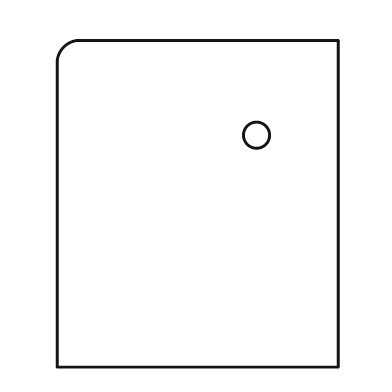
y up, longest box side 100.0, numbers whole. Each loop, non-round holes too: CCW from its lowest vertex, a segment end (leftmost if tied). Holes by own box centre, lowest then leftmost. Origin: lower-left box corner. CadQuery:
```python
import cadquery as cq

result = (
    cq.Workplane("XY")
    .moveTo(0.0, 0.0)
    .lineTo(86.0, 0.0)
    .lineTo(86.0, 100.0)
    .lineTo(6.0, 100.0)
    .threePointArc((2.0, 98.0), (0.0, 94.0))
    .close()
    .moveTo(61.0, 71.0)
    .circle(4.0)
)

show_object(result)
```